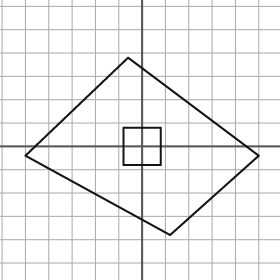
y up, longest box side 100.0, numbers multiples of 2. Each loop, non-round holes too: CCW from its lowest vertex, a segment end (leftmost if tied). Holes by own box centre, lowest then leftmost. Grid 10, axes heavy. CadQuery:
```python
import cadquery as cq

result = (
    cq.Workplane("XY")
    .moveTo(12.0, -38.0)
    .lineTo(50.0, -4.0)
    .lineTo(-6.0, 38.0)
    .lineTo(-50.0, -4.0)
    .close()
    .moveTo(-8.0, -8.0)
    .lineTo(8.0, -8.0)
    .lineTo(8.0, 8.0)
    .lineTo(-8.0, 8.0)
    .close()
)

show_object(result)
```